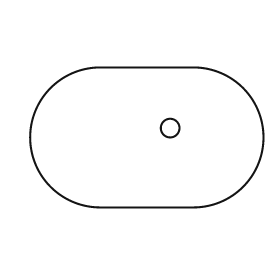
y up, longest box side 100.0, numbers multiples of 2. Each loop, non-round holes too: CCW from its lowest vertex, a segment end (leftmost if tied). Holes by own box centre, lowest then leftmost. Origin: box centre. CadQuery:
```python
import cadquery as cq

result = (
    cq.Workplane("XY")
    .moveTo(-20.0, -30.0)
    .lineTo(20.0, -30.0)
    .threePointArc((50.0, 0.0), (20.0, 30.0))
    .lineTo(-20.0, 30.0)
    .threePointArc((-50.0, 0.0), (-20.0, -30.0))
    .close()
    .moveTo(10.0, 4.0)
    .circle(4.0)
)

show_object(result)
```